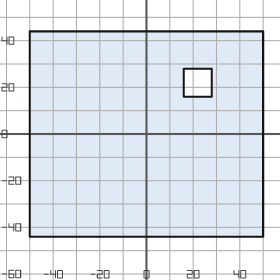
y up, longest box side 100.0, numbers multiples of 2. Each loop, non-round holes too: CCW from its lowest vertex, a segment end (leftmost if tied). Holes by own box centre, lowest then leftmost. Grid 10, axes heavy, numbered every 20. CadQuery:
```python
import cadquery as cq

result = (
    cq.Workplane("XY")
    .moveTo(-50.0, -44.0)
    .lineTo(50.0, -44.0)
    .lineTo(50.0, 44.0)
    .lineTo(-50.0, 44.0)
    .close()
    .moveTo(16.0, 16.0)
    .lineTo(28.0, 16.0)
    .lineTo(28.0, 28.0)
    .lineTo(16.0, 28.0)
    .close()
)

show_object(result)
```